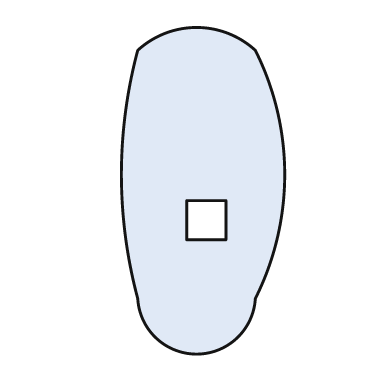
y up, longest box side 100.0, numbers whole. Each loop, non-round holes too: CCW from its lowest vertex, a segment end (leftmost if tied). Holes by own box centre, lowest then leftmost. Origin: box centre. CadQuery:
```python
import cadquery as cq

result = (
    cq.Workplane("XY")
    .moveTo(-20.0, -33.0)
    .threePointArc((-2.0, -50.0), (16.0, -33.0))
    .threePointArc((25.0, 5.0), (16.0, 43.0))
    .threePointArc((-2.0, 50.0), (-20.0, 43.0))
    .threePointArc((-25.0, 5.0), (-20.0, -33.0))
    .close()
    .moveTo(-5.0, -15.0)
    .lineTo(7.0, -15.0)
    .lineTo(7.0, -3.0)
    .lineTo(-5.0, -3.0)
    .close()
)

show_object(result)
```